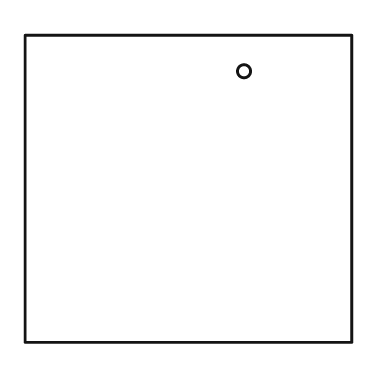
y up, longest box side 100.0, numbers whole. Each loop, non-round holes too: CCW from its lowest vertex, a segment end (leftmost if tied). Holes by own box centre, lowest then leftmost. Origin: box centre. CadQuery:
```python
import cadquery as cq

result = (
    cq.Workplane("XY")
    .moveTo(-50.0, -47.0)
    .lineTo(50.0, -47.0)
    .lineTo(50.0, 47.0)
    .lineTo(-50.0, 47.0)
    .close()
    .moveTo(17.0, 36.0)
    .circle(2.0)
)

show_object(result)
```